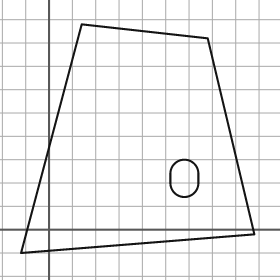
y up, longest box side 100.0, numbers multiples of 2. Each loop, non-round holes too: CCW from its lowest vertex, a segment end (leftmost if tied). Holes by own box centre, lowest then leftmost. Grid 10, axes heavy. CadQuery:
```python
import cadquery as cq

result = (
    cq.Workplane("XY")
    .moveTo(-12.0, -10.0)
    .lineTo(88.0, -2.0)
    .lineTo(68.0, 82.0)
    .lineTo(14.0, 88.0)
    .close()
    .moveTo(52.0, 20.0)
    .threePointArc((58.0, 14.0), (64.0, 20.0))
    .lineTo(64.0, 24.0)
    .threePointArc((58.0, 30.0), (52.0, 24.0))
    .close()
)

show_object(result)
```